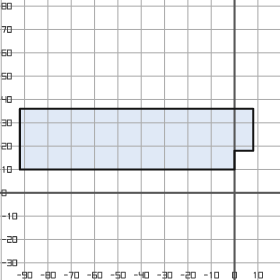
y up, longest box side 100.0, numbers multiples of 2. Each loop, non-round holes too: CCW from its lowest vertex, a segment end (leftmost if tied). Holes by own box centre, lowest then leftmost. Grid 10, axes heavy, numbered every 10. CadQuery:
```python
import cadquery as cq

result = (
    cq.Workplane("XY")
    .moveTo(-92.0, 10.0)
    .lineTo(0.0, 10.0)
    .lineTo(0.0, 18.0)
    .lineTo(8.0, 18.0)
    .lineTo(8.0, 36.0)
    .lineTo(-92.0, 36.0)
    .close()
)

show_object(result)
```